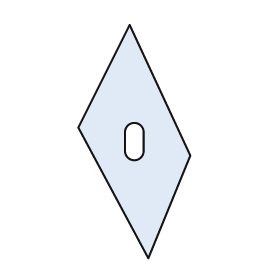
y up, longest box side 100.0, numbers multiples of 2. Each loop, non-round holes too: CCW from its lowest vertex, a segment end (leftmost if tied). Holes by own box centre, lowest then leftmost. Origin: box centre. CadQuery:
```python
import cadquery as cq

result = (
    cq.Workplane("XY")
    .moveTo(6.0, -50.0)
    .lineTo(24.0, -6.0)
    .lineTo(-2.0, 50.0)
    .lineTo(-24.0, 6.0)
    .close()
    .moveTo(-4.0, -4.0)
    .threePointArc((0.0, -8.0), (4.0, -4.0))
    .lineTo(4.0, 4.0)
    .threePointArc((0.0, 8.0), (-4.0, 4.0))
    .close()
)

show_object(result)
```